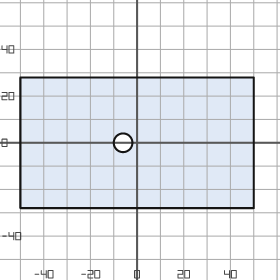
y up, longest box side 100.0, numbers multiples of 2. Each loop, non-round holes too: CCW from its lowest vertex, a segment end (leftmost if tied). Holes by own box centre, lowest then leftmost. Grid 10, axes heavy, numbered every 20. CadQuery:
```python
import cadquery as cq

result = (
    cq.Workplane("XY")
    .moveTo(-50.0, -28.0)
    .lineTo(50.0, -28.0)
    .lineTo(50.0, 28.0)
    .lineTo(-50.0, 28.0)
    .close()
    .moveTo(-6.0, 0.0)
    .circle(4.0)
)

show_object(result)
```